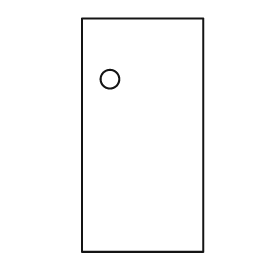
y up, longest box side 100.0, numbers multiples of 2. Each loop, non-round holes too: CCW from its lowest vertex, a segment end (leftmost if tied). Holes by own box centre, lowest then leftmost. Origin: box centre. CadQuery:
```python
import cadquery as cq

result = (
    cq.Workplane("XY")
    .moveTo(-26.0, -50.0)
    .lineTo(26.0, -50.0)
    .lineTo(26.0, 50.0)
    .lineTo(-26.0, 50.0)
    .close()
    .moveTo(-14.0, 24.0)
    .circle(4.0)
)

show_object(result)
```